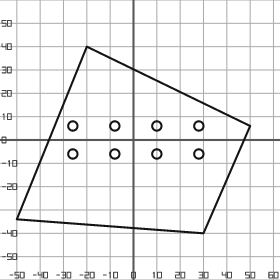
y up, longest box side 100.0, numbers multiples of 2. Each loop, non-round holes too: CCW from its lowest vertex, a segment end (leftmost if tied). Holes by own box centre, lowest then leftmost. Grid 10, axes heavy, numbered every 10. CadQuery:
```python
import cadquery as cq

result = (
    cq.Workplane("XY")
    .moveTo(30.0, -40.0)
    .lineTo(50.0, 6.0)
    .lineTo(-20.0, 40.0)
    .lineTo(-50.0, -34.0)
    .close()
    .moveTo(-26.0, -6.0)
    .circle(2.0)
    .moveTo(-8.0, -6.0)
    .circle(2.0)
    .moveTo(10.0, -6.0)
    .circle(2.0)
    .moveTo(28.0, -6.0)
    .circle(2.0)
    .moveTo(-26.0, 6.0)
    .circle(2.0)
    .moveTo(-8.0, 6.0)
    .circle(2.0)
    .moveTo(10.0, 6.0)
    .circle(2.0)
    .moveTo(28.0, 6.0)
    .circle(2.0)
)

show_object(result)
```